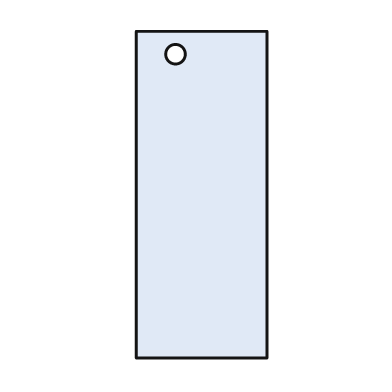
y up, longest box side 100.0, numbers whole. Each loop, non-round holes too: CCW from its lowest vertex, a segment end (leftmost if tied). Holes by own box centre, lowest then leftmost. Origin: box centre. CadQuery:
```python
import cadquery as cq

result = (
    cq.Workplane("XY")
    .moveTo(-20.0, -50.0)
    .lineTo(20.0, -50.0)
    .lineTo(20.0, 50.0)
    .lineTo(-20.0, 50.0)
    .close()
    .moveTo(-8.0, 43.0)
    .circle(3.0)
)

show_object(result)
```